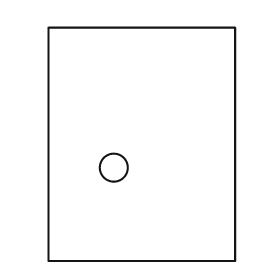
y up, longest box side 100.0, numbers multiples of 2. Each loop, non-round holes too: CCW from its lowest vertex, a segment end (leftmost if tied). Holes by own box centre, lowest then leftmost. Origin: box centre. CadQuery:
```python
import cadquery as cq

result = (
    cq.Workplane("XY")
    .moveTo(-40.0, -50.0)
    .lineTo(40.0, -50.0)
    .lineTo(40.0, 50.0)
    .lineTo(-40.0, 50.0)
    .close()
    .moveTo(-12.0, -10.0)
    .circle(6.0)
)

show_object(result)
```